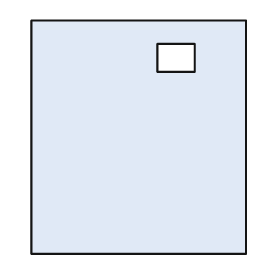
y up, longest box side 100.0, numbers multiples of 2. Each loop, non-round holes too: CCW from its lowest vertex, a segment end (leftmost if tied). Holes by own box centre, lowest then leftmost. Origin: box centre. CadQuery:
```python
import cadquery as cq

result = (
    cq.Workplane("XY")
    .moveTo(-46.0, -50.0)
    .lineTo(46.0, -50.0)
    .lineTo(46.0, 50.0)
    .lineTo(-46.0, 50.0)
    .close()
    .moveTo(8.0, 28.0)
    .lineTo(24.0, 28.0)
    .lineTo(24.0, 40.0)
    .lineTo(8.0, 40.0)
    .close()
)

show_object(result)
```